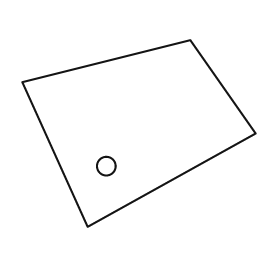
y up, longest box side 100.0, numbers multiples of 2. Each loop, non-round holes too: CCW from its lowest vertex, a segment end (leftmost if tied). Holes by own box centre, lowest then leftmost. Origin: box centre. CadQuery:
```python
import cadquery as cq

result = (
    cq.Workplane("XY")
    .moveTo(-22.0, -40.0)
    .lineTo(50.0, 0.0)
    .lineTo(22.0, 40.0)
    .lineTo(-50.0, 22.0)
    .close()
    .moveTo(-14.0, -14.0)
    .circle(4.0)
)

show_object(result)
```